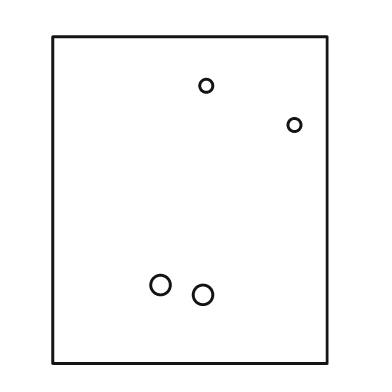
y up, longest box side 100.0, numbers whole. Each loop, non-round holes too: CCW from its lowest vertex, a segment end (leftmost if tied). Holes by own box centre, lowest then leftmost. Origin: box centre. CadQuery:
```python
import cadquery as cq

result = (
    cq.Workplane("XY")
    .moveTo(-42.0, -50.0)
    .lineTo(42.0, -50.0)
    .lineTo(42.0, 50.0)
    .lineTo(-42.0, 50.0)
    .close()
    .moveTo(4.0, -29.0)
    .circle(3.0)
    .moveTo(-9.0, -26.0)
    .circle(3.0)
    .moveTo(32.0, 23.0)
    .circle(2.0)
    .moveTo(5.0, 35.0)
    .circle(2.0)
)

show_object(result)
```